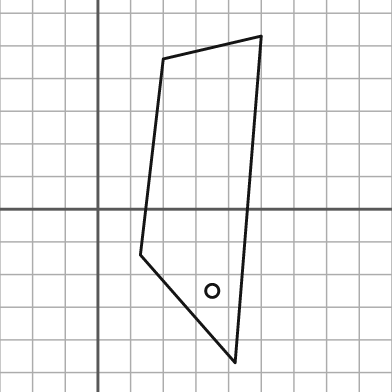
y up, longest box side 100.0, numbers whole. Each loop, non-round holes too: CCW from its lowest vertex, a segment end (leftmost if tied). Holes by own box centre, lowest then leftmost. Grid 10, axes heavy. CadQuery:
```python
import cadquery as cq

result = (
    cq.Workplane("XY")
    .moveTo(42.0, -47.0)
    .lineTo(50.0, 53.0)
    .lineTo(20.0, 46.0)
    .lineTo(13.0, -14.0)
    .close()
    .moveTo(35.0, -25.0)
    .circle(2.0)
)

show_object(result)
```